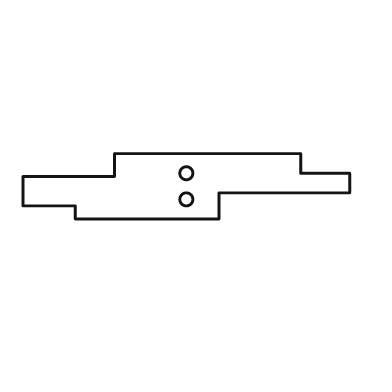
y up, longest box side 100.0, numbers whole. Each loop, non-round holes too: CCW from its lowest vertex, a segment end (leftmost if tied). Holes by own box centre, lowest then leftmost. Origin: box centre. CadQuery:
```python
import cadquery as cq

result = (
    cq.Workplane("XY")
    .moveTo(-34.0, -10.0)
    .lineTo(10.0, -10.0)
    .lineTo(10.0, -2.0)
    .lineTo(50.0, -2.0)
    .lineTo(50.0, 4.0)
    .lineTo(35.0, 4.0)
    .lineTo(35.0, 10.0)
    .lineTo(-22.0, 10.0)
    .lineTo(-22.0, 3.0)
    .lineTo(-50.0, 3.0)
    .lineTo(-50.0, -6.0)
    .lineTo(-34.0, -6.0)
    .close()
    .moveTo(0.0, -4.0)
    .circle(2.0)
    .moveTo(0.0, 4.0)
    .circle(2.0)
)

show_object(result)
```